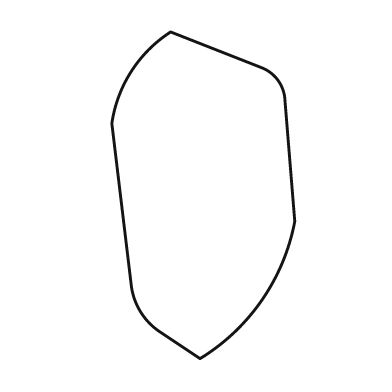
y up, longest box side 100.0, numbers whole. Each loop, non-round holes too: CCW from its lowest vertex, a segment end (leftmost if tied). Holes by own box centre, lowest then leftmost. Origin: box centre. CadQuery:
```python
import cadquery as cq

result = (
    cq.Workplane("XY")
    .moveTo(-1.0, -50.0)
    .threePointArc((18.0, -32.0), (28.0, -8.0))
    .lineTo(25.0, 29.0)
    .threePointArc((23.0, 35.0), (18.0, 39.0))
    .lineTo(-10.0, 50.0)
    .threePointArc((-22.0, 38.0), (-28.0, 22.0))
    .lineTo(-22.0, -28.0)
    .threePointArc((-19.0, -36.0), (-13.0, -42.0))
    .close()
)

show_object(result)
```